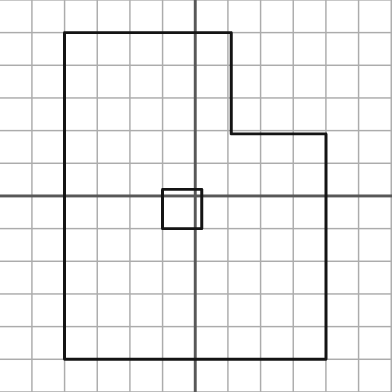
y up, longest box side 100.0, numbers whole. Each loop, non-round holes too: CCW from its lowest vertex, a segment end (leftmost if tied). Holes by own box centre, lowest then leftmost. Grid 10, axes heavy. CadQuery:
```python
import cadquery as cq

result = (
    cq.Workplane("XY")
    .moveTo(-40.0, -50.0)
    .lineTo(40.0, -50.0)
    .lineTo(40.0, 19.0)
    .lineTo(11.0, 19.0)
    .lineTo(11.0, 50.0)
    .lineTo(-40.0, 50.0)
    .close()
    .moveTo(-10.0, -10.0)
    .lineTo(2.0, -10.0)
    .lineTo(2.0, 2.0)
    .lineTo(-10.0, 2.0)
    .close()
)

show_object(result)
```